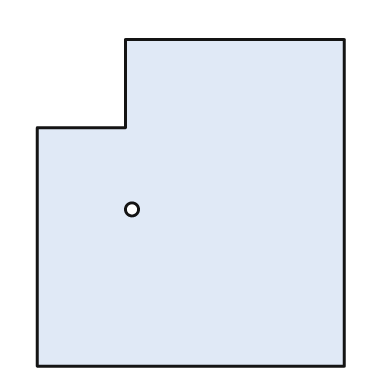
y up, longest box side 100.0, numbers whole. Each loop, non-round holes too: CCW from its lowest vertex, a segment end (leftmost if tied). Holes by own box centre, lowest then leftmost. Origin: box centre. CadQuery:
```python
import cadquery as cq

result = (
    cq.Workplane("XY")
    .moveTo(-47.0, -50.0)
    .lineTo(47.0, -50.0)
    .lineTo(47.0, 50.0)
    .lineTo(-20.0, 50.0)
    .lineTo(-20.0, 23.0)
    .lineTo(-47.0, 23.0)
    .close()
    .moveTo(-18.0, -2.0)
    .circle(2.0)
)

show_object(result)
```